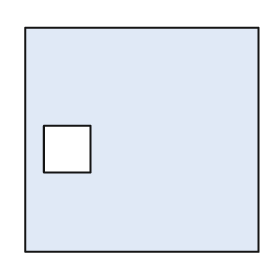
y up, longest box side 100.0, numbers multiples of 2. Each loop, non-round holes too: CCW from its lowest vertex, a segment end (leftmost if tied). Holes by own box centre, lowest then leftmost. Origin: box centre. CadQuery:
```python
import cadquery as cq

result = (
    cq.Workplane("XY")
    .moveTo(-50.0, -48.0)
    .lineTo(50.0, -48.0)
    .lineTo(50.0, 48.0)
    .lineTo(-50.0, 48.0)
    .close()
    .moveTo(-42.0, -14.0)
    .lineTo(-22.0, -14.0)
    .lineTo(-22.0, 6.0)
    .lineTo(-42.0, 6.0)
    .close()
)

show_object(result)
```